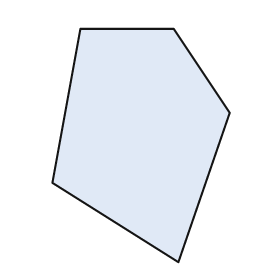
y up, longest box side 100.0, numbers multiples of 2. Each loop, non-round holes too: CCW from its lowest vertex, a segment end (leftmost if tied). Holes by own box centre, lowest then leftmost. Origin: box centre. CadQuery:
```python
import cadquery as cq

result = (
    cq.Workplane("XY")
    .moveTo(16.0, -50.0)
    .lineTo(38.0, 14.0)
    .lineTo(14.0, 50.0)
    .lineTo(-26.0, 50.0)
    .lineTo(-38.0, -16.0)
    .close()
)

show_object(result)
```